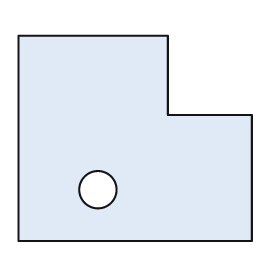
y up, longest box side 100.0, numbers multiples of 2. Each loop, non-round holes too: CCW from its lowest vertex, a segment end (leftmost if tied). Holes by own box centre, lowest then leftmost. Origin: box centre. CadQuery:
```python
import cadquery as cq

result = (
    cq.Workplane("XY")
    .moveTo(-50.0, -44.0)
    .lineTo(50.0, -44.0)
    .lineTo(50.0, 10.0)
    .lineTo(14.0, 10.0)
    .lineTo(14.0, 44.0)
    .lineTo(-50.0, 44.0)
    .close()
    .moveTo(-16.0, -22.0)
    .circle(8.0)
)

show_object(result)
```